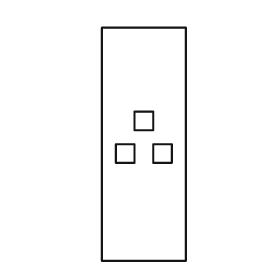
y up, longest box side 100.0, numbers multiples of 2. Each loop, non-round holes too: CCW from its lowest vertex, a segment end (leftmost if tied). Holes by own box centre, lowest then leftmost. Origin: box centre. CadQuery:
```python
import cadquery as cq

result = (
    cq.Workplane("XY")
    .moveTo(-18.0, -50.0)
    .lineTo(18.0, -50.0)
    .lineTo(18.0, 50.0)
    .lineTo(-18.0, 50.0)
    .close()
    .moveTo(-12.0, -8.0)
    .lineTo(-4.0, -8.0)
    .lineTo(-4.0, 0.0)
    .lineTo(-12.0, 0.0)
    .close()
    .moveTo(4.0, -8.0)
    .lineTo(12.0, -8.0)
    .lineTo(12.0, 0.0)
    .lineTo(4.0, 0.0)
    .close()
    .moveTo(-4.0, 6.0)
    .lineTo(4.0, 6.0)
    .lineTo(4.0, 14.0)
    .lineTo(-4.0, 14.0)
    .close()
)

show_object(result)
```